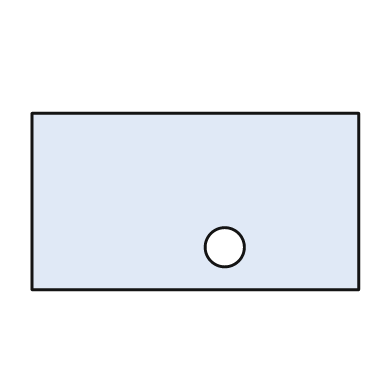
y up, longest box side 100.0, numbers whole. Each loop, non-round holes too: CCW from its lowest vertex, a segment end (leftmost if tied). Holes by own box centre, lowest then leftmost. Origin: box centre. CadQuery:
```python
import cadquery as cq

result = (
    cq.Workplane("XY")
    .moveTo(-50.0, -27.0)
    .lineTo(50.0, -27.0)
    .lineTo(50.0, 27.0)
    .lineTo(-50.0, 27.0)
    .close()
    .moveTo(9.0, -14.0)
    .circle(6.0)
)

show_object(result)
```